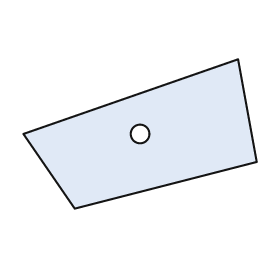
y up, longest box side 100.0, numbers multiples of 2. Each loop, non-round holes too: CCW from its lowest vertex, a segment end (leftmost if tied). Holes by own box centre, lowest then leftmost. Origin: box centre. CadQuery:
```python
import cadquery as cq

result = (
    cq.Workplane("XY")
    .moveTo(-28.0, -32.0)
    .lineTo(50.0, -12.0)
    .lineTo(42.0, 32.0)
    .lineTo(-50.0, 0.0)
    .close()
    .moveTo(0.0, 0.0)
    .circle(4.0)
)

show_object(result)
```